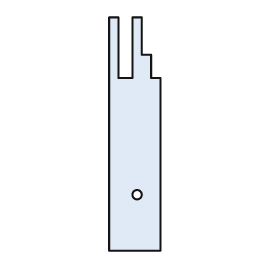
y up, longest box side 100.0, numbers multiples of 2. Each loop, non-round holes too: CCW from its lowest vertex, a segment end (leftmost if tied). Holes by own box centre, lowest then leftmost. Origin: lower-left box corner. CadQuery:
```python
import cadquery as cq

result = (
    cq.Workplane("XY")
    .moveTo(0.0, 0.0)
    .lineTo(22.0, 0.0)
    .lineTo(22.0, 74.0)
    .lineTo(18.0, 74.0)
    .lineTo(18.0, 84.0)
    .lineTo(14.0, 84.0)
    .lineTo(14.0, 100.0)
    .lineTo(10.0, 100.0)
    .lineTo(10.0, 74.0)
    .lineTo(4.0, 74.0)
    .lineTo(4.0, 100.0)
    .lineTo(0.0, 100.0)
    .close()
    .moveTo(12.0, 24.0)
    .circle(2.0)
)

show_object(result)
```